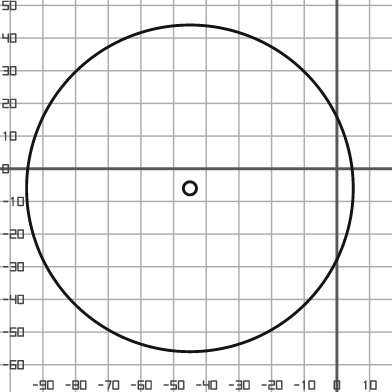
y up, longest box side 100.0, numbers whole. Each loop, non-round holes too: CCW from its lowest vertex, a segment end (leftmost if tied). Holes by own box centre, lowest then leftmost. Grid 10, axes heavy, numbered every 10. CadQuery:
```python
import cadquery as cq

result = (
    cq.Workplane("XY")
    .moveTo(-45.0, -6.0)
    .circle(50.0)
    .moveTo(-45.0, -6.0)
    .circle(2.0)
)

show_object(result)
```